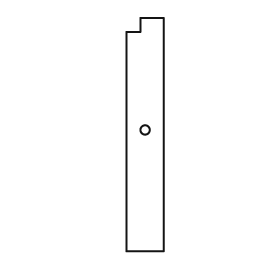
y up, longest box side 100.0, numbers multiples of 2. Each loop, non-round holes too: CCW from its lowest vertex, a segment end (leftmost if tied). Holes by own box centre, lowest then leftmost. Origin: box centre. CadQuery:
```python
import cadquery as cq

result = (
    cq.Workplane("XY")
    .moveTo(-8.0, -50.0)
    .lineTo(8.0, -50.0)
    .lineTo(8.0, 50.0)
    .lineTo(-2.0, 50.0)
    .lineTo(-2.0, 44.0)
    .lineTo(-8.0, 44.0)
    .close()
    .moveTo(0.0, 2.0)
    .circle(2.0)
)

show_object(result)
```